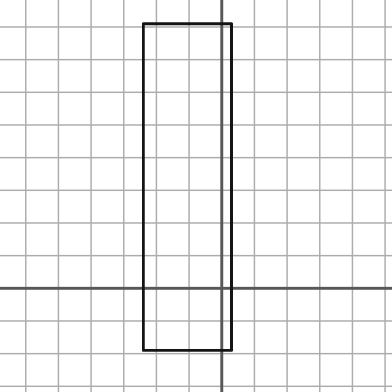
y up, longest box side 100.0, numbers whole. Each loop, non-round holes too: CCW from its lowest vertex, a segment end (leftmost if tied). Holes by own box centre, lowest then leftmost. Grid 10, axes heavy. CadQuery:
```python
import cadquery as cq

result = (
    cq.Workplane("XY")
    .moveTo(-24.0, -19.0)
    .lineTo(3.0, -19.0)
    .lineTo(3.0, 81.0)
    .lineTo(-24.0, 81.0)
    .close()
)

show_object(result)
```